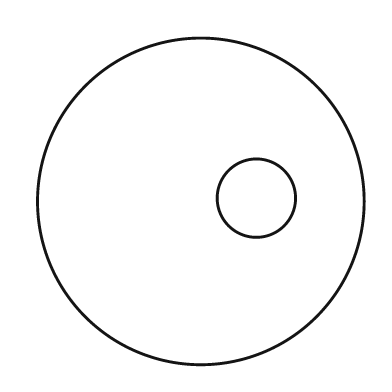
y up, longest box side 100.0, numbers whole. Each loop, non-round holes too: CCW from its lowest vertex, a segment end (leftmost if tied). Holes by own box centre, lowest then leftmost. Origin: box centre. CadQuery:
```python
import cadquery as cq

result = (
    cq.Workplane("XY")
    .moveTo(0.0, 0.0)
    .circle(50.0)
    .moveTo(17.0, 1.0)
    .circle(12.0)
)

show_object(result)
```